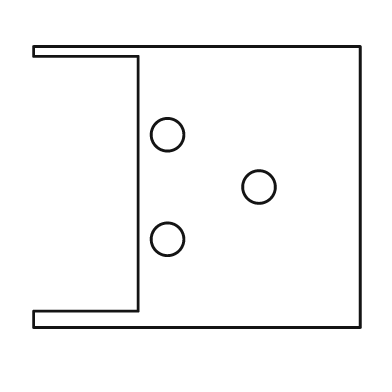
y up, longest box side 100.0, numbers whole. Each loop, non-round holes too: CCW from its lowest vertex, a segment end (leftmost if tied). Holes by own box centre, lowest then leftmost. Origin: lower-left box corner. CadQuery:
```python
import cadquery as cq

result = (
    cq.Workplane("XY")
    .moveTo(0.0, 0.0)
    .lineTo(100.0, 0.0)
    .lineTo(100.0, 86.0)
    .lineTo(0.0, 86.0)
    .lineTo(0.0, 83.0)
    .lineTo(32.0, 83.0)
    .lineTo(32.0, 5.0)
    .lineTo(0.0, 5.0)
    .close()
    .moveTo(41.0, 27.0)
    .circle(5.0)
    .moveTo(69.0, 43.0)
    .circle(5.0)
    .moveTo(41.0, 59.0)
    .circle(5.0)
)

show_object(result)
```